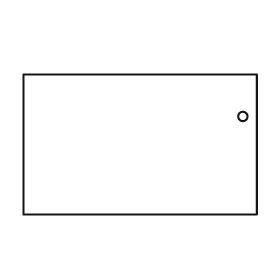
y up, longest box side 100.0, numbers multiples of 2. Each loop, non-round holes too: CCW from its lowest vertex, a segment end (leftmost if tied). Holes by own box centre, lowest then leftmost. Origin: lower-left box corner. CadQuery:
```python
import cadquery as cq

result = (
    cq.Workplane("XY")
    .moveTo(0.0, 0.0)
    .lineTo(100.0, 0.0)
    .lineTo(100.0, 60.0)
    .lineTo(0.0, 60.0)
    .close()
    .moveTo(94.0, 42.0)
    .circle(2.0)
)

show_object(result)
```